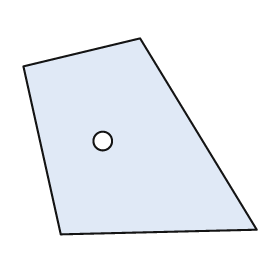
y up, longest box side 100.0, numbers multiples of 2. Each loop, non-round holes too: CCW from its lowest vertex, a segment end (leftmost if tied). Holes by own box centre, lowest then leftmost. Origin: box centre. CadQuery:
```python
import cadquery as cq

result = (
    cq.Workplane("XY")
    .moveTo(-34.0, -42.0)
    .lineTo(50.0, -40.0)
    .lineTo(0.0, 42.0)
    .lineTo(-50.0, 30.0)
    .close()
    .moveTo(-16.0, -2.0)
    .circle(4.0)
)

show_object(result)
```